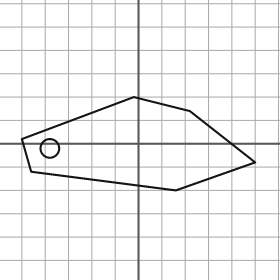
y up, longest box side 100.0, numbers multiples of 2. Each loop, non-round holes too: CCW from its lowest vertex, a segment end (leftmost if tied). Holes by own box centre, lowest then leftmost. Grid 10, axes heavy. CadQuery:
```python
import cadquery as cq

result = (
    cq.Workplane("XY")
    .moveTo(16.0, -20.0)
    .lineTo(50.0, -8.0)
    .lineTo(22.0, 14.0)
    .lineTo(-2.0, 20.0)
    .lineTo(-50.0, 2.0)
    .lineTo(-46.0, -12.0)
    .close()
    .moveTo(-38.0, -2.0)
    .circle(4.0)
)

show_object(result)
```